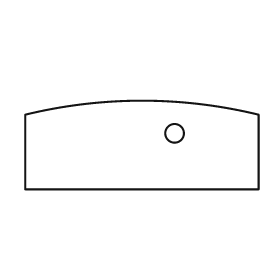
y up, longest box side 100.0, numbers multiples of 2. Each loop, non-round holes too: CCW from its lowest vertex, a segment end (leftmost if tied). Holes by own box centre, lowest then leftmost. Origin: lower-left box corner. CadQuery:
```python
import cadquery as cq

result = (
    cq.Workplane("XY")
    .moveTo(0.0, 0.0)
    .lineTo(100.0, 0.0)
    .lineTo(100.0, 32.0)
    .threePointArc((50.0, 38.0), (0.0, 32.0))
    .close()
    .moveTo(64.0, 24.0)
    .circle(4.0)
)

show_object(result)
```